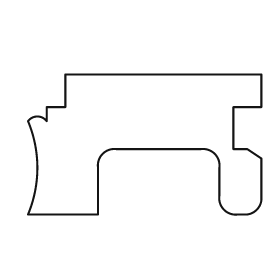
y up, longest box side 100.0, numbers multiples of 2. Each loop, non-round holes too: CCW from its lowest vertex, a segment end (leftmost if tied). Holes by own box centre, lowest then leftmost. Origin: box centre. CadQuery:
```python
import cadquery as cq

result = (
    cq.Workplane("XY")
    .moveTo(-50.0, -30.0)
    .lineTo(-20.0, -30.0)
    .lineTo(-20.0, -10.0)
    .threePointArc((-18.0, -4.0), (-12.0, -2.0))
    .lineTo(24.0, -2.0)
    .threePointArc((30.0, -4.0), (32.0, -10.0))
    .lineTo(32.0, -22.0)
    .threePointArc((34.0, -28.0), (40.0, -30.0))
    .lineTo(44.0, -30.0)
    .threePointArc((48.0, -28.0), (50.0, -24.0))
    .lineTo(50.0, -6.0)
    .lineTo(44.0, -2.0)
    .lineTo(38.0, -2.0)
    .lineTo(38.0, 16.0)
    .lineTo(50.0, 16.0)
    .lineTo(50.0, 30.0)
    .lineTo(-34.0, 30.0)
    .lineTo(-34.0, 16.0)
    .lineTo(-42.0, 16.0)
    .lineTo(-42.0, 10.0)
    .threePointArc((-46.0, 12.0), (-50.0, 10.0))
    .threePointArc((-46.0, -10.0), (-50.0, -30.0))
    .close()
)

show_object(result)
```